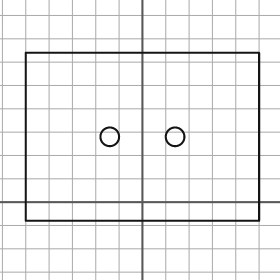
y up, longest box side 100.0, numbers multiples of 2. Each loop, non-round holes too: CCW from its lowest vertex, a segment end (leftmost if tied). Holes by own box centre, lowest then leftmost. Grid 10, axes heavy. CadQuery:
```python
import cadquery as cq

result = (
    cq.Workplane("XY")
    .moveTo(-50.0, -8.0)
    .lineTo(50.0, -8.0)
    .lineTo(50.0, 64.0)
    .lineTo(-50.0, 64.0)
    .close()
    .moveTo(-14.0, 28.0)
    .circle(4.0)
    .moveTo(14.0, 28.0)
    .circle(4.0)
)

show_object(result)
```